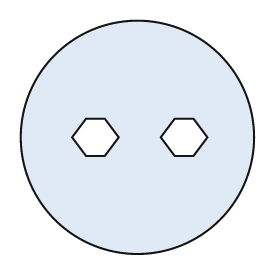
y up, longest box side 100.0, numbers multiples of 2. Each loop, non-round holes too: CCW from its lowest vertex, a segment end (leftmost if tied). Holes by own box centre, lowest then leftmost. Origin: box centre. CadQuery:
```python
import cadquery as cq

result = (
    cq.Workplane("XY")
    .moveTo(0.0, 0.0)
    .circle(50.0)
    .moveTo(-22.0, -8.0)
    .lineTo(-14.0, -8.0)
    .lineTo(-8.0, 0.0)
    .lineTo(-14.0, 8.0)
    .lineTo(-22.0, 8.0)
    .lineTo(-28.0, 0.0)
    .close()
    .moveTo(16.0, -8.0)
    .lineTo(24.0, -8.0)
    .lineTo(30.0, 0.0)
    .lineTo(24.0, 8.0)
    .lineTo(16.0, 8.0)
    .lineTo(10.0, 0.0)
    .close()
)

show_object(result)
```